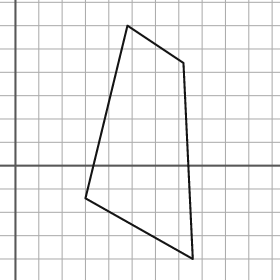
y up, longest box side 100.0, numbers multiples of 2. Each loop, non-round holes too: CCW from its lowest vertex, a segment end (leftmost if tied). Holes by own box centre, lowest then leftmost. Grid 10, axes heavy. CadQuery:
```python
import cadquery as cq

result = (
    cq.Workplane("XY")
    .moveTo(76.0, -40.0)
    .lineTo(72.0, 44.0)
    .lineTo(48.0, 60.0)
    .lineTo(30.0, -14.0)
    .close()
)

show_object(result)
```